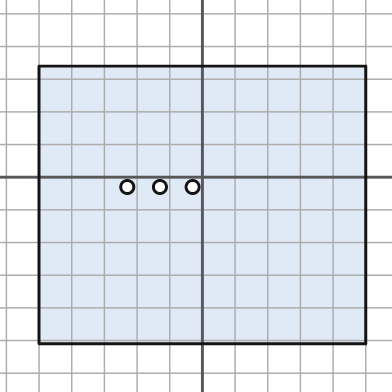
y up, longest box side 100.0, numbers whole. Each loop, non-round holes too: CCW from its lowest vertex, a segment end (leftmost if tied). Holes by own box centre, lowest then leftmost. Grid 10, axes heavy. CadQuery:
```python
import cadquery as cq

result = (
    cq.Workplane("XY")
    .moveTo(-50.0, -51.0)
    .lineTo(50.0, -51.0)
    .lineTo(50.0, 34.0)
    .lineTo(-50.0, 34.0)
    .close()
    .moveTo(-23.0, -3.0)
    .circle(2.0)
    .moveTo(-13.0, -3.0)
    .circle(2.0)
    .moveTo(-3.0, -3.0)
    .circle(2.0)
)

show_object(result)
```